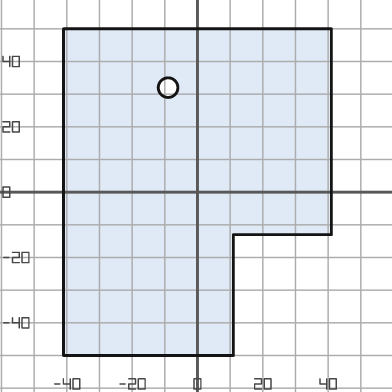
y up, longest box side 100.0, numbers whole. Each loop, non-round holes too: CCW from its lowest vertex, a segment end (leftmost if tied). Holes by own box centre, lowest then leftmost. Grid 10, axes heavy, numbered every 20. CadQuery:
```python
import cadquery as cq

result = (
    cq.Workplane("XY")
    .moveTo(-41.0, -50.0)
    .lineTo(11.0, -50.0)
    .lineTo(11.0, -13.0)
    .lineTo(41.0, -13.0)
    .lineTo(41.0, 50.0)
    .lineTo(-41.0, 50.0)
    .close()
    .moveTo(-9.0, 32.0)
    .circle(3.0)
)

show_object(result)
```